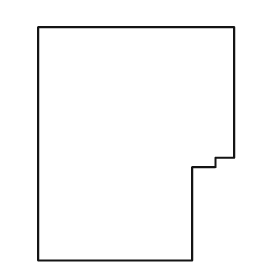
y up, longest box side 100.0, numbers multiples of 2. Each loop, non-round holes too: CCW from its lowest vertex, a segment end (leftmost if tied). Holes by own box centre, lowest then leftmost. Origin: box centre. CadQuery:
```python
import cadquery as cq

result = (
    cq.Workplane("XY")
    .moveTo(-42.0, -50.0)
    .lineTo(24.0, -50.0)
    .lineTo(24.0, -10.0)
    .lineTo(34.0, -10.0)
    .lineTo(34.0, -6.0)
    .lineTo(42.0, -6.0)
    .lineTo(42.0, 50.0)
    .lineTo(-42.0, 50.0)
    .close()
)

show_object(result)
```